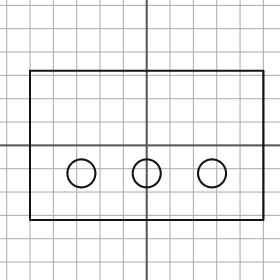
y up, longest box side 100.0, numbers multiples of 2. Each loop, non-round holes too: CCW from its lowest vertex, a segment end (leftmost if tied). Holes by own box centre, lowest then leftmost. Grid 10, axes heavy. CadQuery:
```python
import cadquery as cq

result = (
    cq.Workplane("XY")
    .moveTo(-50.0, -32.0)
    .lineTo(50.0, -32.0)
    .lineTo(50.0, 32.0)
    .lineTo(-50.0, 32.0)
    .close()
    .moveTo(-28.0, -12.0)
    .circle(6.0)
    .moveTo(0.0, -12.0)
    .circle(6.0)
    .moveTo(28.0, -12.0)
    .circle(6.0)
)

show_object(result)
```